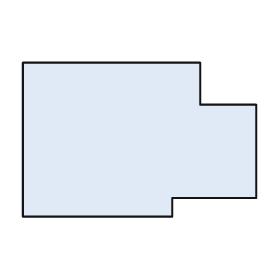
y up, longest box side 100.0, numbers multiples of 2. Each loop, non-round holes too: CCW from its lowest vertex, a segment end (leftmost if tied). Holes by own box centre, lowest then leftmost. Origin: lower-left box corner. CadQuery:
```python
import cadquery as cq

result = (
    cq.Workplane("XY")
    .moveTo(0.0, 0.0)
    .lineTo(64.0, 0.0)
    .lineTo(64.0, 8.0)
    .lineTo(100.0, 8.0)
    .lineTo(100.0, 48.0)
    .lineTo(76.0, 48.0)
    .lineTo(76.0, 66.0)
    .lineTo(0.0, 66.0)
    .close()
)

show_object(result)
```